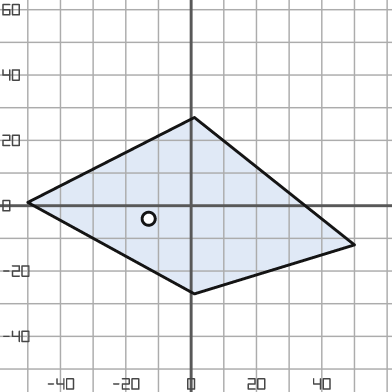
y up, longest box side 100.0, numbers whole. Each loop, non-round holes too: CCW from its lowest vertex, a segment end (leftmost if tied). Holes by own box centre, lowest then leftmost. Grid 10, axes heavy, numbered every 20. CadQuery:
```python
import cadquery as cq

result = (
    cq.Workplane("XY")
    .moveTo(1.0, -27.0)
    .lineTo(50.0, -12.0)
    .lineTo(1.0, 27.0)
    .lineTo(-50.0, 1.0)
    .close()
    .moveTo(-13.0, -4.0)
    .circle(2.0)
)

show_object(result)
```